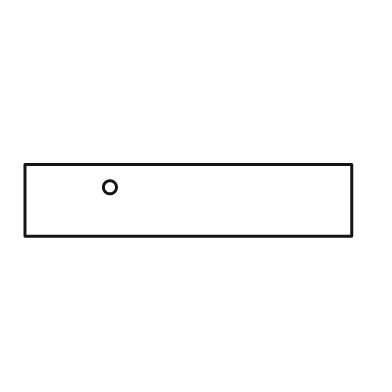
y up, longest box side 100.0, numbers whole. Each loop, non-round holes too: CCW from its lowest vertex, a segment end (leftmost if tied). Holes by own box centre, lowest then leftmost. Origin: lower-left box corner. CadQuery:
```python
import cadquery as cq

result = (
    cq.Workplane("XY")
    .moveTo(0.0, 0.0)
    .lineTo(100.0, 0.0)
    .lineTo(100.0, 22.0)
    .lineTo(0.0, 22.0)
    .close()
    .moveTo(26.0, 15.0)
    .circle(2.0)
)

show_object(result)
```